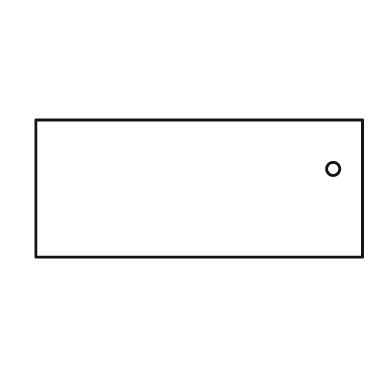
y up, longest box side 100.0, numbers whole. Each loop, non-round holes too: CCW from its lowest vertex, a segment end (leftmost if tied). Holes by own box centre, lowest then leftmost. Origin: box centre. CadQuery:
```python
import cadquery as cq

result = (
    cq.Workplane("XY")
    .moveTo(-50.0, -21.0)
    .lineTo(50.0, -21.0)
    .lineTo(50.0, 21.0)
    .lineTo(-50.0, 21.0)
    .close()
    .moveTo(41.0, 6.0)
    .circle(2.0)
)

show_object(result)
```